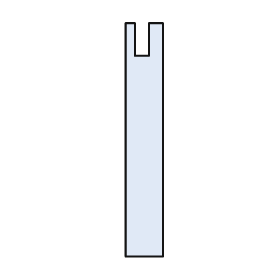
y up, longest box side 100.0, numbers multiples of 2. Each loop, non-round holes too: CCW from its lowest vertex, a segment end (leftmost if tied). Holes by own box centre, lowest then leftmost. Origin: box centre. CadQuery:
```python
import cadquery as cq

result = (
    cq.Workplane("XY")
    .moveTo(-8.0, -50.0)
    .lineTo(8.0, -50.0)
    .lineTo(8.0, 50.0)
    .lineTo(2.0, 50.0)
    .lineTo(2.0, 36.0)
    .lineTo(-4.0, 36.0)
    .lineTo(-4.0, 50.0)
    .lineTo(-8.0, 50.0)
    .close()
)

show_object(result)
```